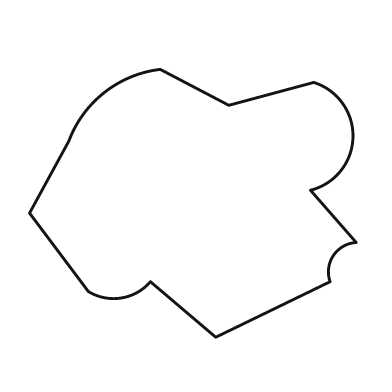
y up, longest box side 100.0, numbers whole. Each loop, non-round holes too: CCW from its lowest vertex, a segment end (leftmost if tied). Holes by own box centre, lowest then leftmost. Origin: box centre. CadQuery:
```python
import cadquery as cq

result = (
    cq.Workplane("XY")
    .moveTo(7.0, -41.0)
    .lineTo(42.0, -24.0)
    .threePointArc((43.0, -16.0), (50.0, -12.0))
    .lineTo(36.0, 4.0)
    .threePointArc((49.0, 20.0), (37.0, 37.0))
    .lineTo(11.0, 30.0)
    .lineTo(-10.0, 41.0)
    .threePointArc((-27.0, 34.0), (-38.0, 19.0))
    .lineTo(-50.0, -3.0)
    .lineTo(-32.0, -27.0)
    .threePointArc((-22.0, -29.0), (-13.0, -24.0))
    .close()
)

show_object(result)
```